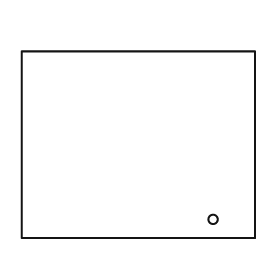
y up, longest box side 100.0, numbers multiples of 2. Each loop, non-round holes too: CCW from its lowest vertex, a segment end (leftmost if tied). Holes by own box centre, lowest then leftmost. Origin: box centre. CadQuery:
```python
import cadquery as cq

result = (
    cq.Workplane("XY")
    .moveTo(-50.0, -40.0)
    .lineTo(50.0, -40.0)
    .lineTo(50.0, 40.0)
    .lineTo(-50.0, 40.0)
    .close()
    .moveTo(32.0, -32.0)
    .circle(2.0)
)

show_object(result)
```